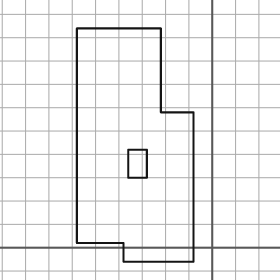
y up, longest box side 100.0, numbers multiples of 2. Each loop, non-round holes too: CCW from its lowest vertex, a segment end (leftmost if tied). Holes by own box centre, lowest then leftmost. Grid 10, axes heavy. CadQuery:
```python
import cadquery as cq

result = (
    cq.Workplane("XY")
    .moveTo(-38.0, -6.0)
    .lineTo(-8.0, -6.0)
    .lineTo(-8.0, 58.0)
    .lineTo(-22.0, 58.0)
    .lineTo(-22.0, 94.0)
    .lineTo(-58.0, 94.0)
    .lineTo(-58.0, 2.0)
    .lineTo(-38.0, 2.0)
    .close()
    .moveTo(-36.0, 30.0)
    .lineTo(-28.0, 30.0)
    .lineTo(-28.0, 42.0)
    .lineTo(-36.0, 42.0)
    .close()
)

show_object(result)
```